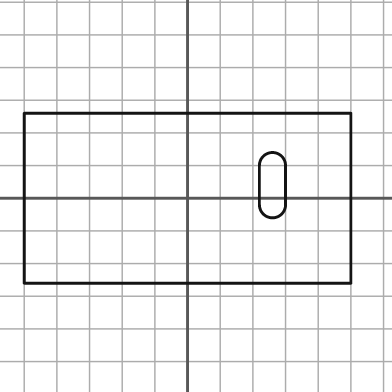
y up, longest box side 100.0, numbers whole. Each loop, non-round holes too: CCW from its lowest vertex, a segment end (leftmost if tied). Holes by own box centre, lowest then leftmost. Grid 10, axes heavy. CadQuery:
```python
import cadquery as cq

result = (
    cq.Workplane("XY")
    .moveTo(-50.0, -26.0)
    .lineTo(50.0, -26.0)
    .lineTo(50.0, 26.0)
    .lineTo(-50.0, 26.0)
    .close()
    .moveTo(22.0, -2.0)
    .threePointArc((26.0, -6.0), (30.0, -2.0))
    .lineTo(30.0, 10.0)
    .threePointArc((26.0, 14.0), (22.0, 10.0))
    .close()
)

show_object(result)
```